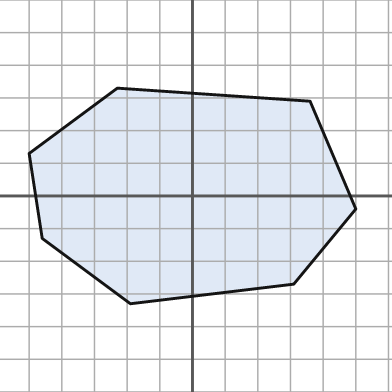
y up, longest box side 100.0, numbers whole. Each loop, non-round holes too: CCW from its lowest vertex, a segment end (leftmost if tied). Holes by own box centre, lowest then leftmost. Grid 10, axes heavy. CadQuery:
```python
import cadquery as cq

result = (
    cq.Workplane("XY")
    .moveTo(-19.0, -33.0)
    .lineTo(31.0, -27.0)
    .lineTo(50.0, -4.0)
    .lineTo(36.0, 29.0)
    .lineTo(-23.0, 33.0)
    .lineTo(-50.0, 13.0)
    .lineTo(-46.0, -13.0)
    .close()
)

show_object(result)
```